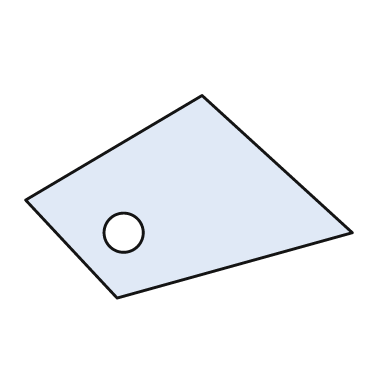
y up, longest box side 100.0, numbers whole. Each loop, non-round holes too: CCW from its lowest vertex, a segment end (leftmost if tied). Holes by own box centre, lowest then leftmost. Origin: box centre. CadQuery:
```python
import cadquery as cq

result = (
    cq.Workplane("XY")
    .moveTo(-22.0, -31.0)
    .lineTo(50.0, -11.0)
    .lineTo(4.0, 31.0)
    .lineTo(-50.0, -1.0)
    .close()
    .moveTo(-20.0, -11.0)
    .circle(6.0)
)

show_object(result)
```